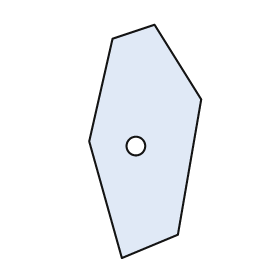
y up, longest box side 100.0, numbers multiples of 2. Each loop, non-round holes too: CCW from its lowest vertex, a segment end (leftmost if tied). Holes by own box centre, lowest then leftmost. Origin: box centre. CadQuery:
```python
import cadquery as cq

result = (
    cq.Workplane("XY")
    .moveTo(-10.0, -50.0)
    .lineTo(14.0, -40.0)
    .lineTo(24.0, 18.0)
    .lineTo(4.0, 50.0)
    .lineTo(-14.0, 44.0)
    .lineTo(-24.0, 0.0)
    .close()
    .moveTo(-4.0, -2.0)
    .circle(4.0)
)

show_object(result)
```